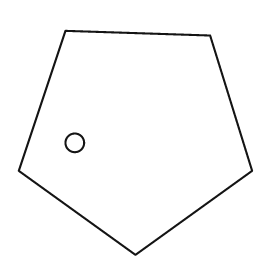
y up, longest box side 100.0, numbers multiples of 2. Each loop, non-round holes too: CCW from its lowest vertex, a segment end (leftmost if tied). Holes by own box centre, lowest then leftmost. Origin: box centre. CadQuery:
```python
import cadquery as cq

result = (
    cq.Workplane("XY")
    .moveTo(0.0, -48.0)
    .lineTo(50.0, -12.0)
    .lineTo(32.0, 46.0)
    .lineTo(-30.0, 48.0)
    .lineTo(-50.0, -12.0)
    .close()
    .moveTo(-26.0, 0.0)
    .circle(4.0)
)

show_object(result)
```